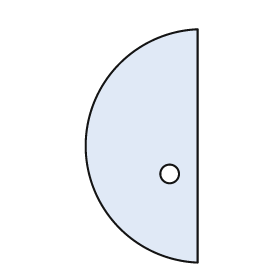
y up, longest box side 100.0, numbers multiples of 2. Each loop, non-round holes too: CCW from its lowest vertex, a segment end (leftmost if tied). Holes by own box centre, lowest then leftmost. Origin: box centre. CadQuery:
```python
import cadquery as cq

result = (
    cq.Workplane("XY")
    .moveTo(24.0, -50.0)
    .lineTo(24.0, 50.0)
    .threePointArc((-24.0, 0.0), (24.0, -50.0))
    .close()
    .moveTo(12.0, -12.0)
    .circle(4.0)
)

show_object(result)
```